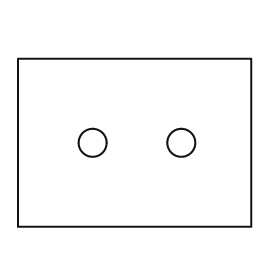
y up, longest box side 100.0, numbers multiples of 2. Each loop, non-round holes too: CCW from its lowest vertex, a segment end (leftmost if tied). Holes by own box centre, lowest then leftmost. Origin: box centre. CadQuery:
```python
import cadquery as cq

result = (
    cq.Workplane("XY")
    .moveTo(-50.0, -36.0)
    .lineTo(50.0, -36.0)
    .lineTo(50.0, 36.0)
    .lineTo(-50.0, 36.0)
    .close()
    .moveTo(-18.0, 0.0)
    .circle(6.0)
    .moveTo(20.0, 0.0)
    .circle(6.0)
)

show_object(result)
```